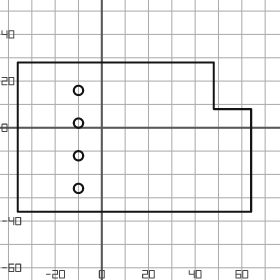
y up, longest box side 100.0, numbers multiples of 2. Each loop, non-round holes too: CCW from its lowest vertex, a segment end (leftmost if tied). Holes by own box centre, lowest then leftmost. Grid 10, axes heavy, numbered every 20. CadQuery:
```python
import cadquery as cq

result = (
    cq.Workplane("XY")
    .moveTo(-36.0, -36.0)
    .lineTo(64.0, -36.0)
    .lineTo(64.0, 8.0)
    .lineTo(48.0, 8.0)
    .lineTo(48.0, 28.0)
    .lineTo(-36.0, 28.0)
    .close()
    .moveTo(-10.0, -26.0)
    .circle(2.0)
    .moveTo(-10.0, -12.0)
    .circle(2.0)
    .moveTo(-10.0, 2.0)
    .circle(2.0)
    .moveTo(-10.0, 16.0)
    .circle(2.0)
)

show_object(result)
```